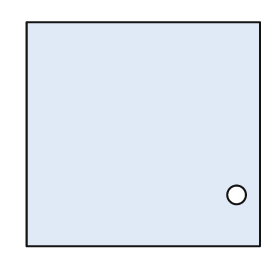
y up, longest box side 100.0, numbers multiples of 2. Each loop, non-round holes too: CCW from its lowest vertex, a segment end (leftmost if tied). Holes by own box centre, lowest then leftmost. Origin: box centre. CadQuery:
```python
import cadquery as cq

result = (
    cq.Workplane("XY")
    .moveTo(-50.0, -48.0)
    .lineTo(50.0, -48.0)
    .lineTo(50.0, 48.0)
    .lineTo(-50.0, 48.0)
    .close()
    .moveTo(40.0, -26.0)
    .circle(4.0)
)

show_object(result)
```